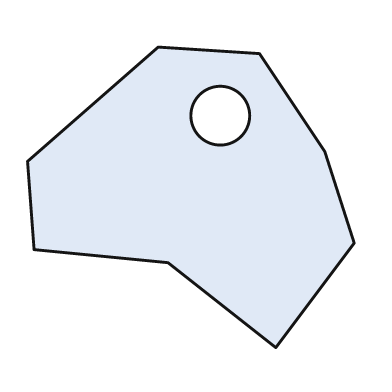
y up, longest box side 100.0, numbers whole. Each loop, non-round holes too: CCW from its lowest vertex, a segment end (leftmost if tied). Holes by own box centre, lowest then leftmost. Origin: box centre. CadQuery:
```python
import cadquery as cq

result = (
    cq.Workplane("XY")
    .moveTo(26.0, -46.0)
    .lineTo(50.0, -14.0)
    .lineTo(41.0, 14.0)
    .lineTo(21.0, 44.0)
    .lineTo(-10.0, 46.0)
    .lineTo(-50.0, 11.0)
    .lineTo(-48.0, -16.0)
    .lineTo(-7.0, -20.0)
    .close()
    .moveTo(9.0, 25.0)
    .circle(9.0)
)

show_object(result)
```